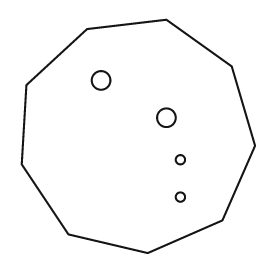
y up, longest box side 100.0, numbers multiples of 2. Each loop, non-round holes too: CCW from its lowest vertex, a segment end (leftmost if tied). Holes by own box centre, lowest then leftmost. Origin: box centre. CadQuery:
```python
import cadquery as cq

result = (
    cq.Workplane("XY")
    .moveTo(4.0, -50.0)
    .lineTo(36.0, -36.0)
    .lineTo(50.0, -4.0)
    .lineTo(40.0, 30.0)
    .lineTo(12.0, 50.0)
    .lineTo(-22.0, 46.0)
    .lineTo(-48.0, 22.0)
    .lineTo(-50.0, -12.0)
    .lineTo(-30.0, -42.0)
    .close()
    .moveTo(18.0, -26.0)
    .circle(2.0)
    .moveTo(18.0, -10.0)
    .circle(2.0)
    .moveTo(12.0, 8.0)
    .circle(4.0)
    .moveTo(-16.0, 24.0)
    .circle(4.0)
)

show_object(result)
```